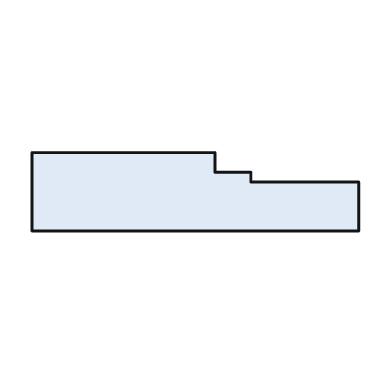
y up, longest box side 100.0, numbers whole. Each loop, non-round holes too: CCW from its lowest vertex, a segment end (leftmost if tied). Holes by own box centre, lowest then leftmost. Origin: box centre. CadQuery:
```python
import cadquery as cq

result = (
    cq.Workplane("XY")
    .moveTo(-50.0, -12.0)
    .lineTo(50.0, -12.0)
    .lineTo(50.0, 3.0)
    .lineTo(17.0, 3.0)
    .lineTo(17.0, 6.0)
    .lineTo(6.0, 6.0)
    .lineTo(6.0, 12.0)
    .lineTo(-50.0, 12.0)
    .close()
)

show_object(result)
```